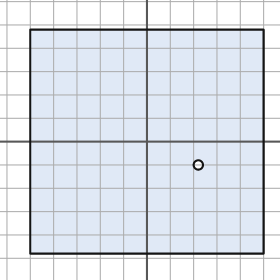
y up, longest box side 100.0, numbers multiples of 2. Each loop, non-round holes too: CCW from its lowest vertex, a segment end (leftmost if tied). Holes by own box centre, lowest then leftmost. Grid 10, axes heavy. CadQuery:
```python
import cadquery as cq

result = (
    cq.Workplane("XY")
    .moveTo(-50.0, -48.0)
    .lineTo(50.0, -48.0)
    .lineTo(50.0, 48.0)
    .lineTo(-50.0, 48.0)
    .close()
    .moveTo(22.0, -10.0)
    .circle(2.0)
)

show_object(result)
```